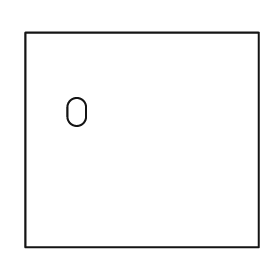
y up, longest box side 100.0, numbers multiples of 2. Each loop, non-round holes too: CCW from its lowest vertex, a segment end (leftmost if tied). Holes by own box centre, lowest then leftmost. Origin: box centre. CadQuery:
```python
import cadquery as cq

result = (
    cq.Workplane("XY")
    .moveTo(-50.0, -46.0)
    .lineTo(50.0, -46.0)
    .lineTo(50.0, 46.0)
    .lineTo(-50.0, 46.0)
    .close()
    .moveTo(-32.0, 10.0)
    .threePointArc((-28.0, 6.0), (-24.0, 10.0))
    .lineTo(-24.0, 14.0)
    .threePointArc((-28.0, 18.0), (-32.0, 14.0))
    .close()
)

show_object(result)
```